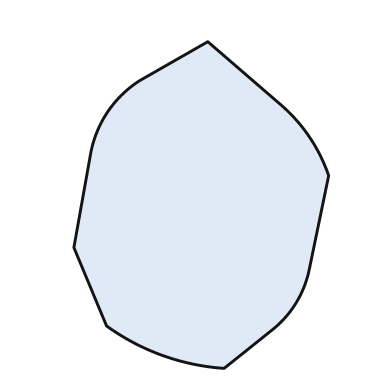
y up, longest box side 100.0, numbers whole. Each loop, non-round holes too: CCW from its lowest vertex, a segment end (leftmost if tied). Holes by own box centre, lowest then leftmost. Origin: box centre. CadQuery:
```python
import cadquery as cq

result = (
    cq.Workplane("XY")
    .moveTo(7.0, -50.0)
    .lineTo(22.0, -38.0)
    .threePointArc((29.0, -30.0), (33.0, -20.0))
    .lineTo(39.0, 9.0)
    .threePointArc((33.0, 21.0), (24.0, 31.0))
    .lineTo(2.0, 50.0)
    .lineTo(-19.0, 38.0)
    .threePointArc((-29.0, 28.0), (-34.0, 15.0))
    .lineTo(-39.0, -13.0)
    .lineTo(-29.0, -37.0)
    .threePointArc((-12.0, -46.0), (7.0, -50.0))
    .close()
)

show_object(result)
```